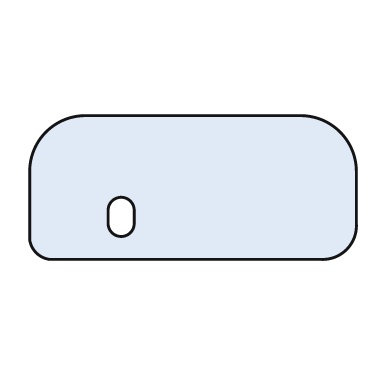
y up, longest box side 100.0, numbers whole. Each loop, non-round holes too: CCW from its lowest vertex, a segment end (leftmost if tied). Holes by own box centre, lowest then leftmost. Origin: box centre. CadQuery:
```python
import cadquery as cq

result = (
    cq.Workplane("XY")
    .moveTo(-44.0, -22.0)
    .lineTo(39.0, -22.0)
    .threePointArc((47.0, -19.0), (50.0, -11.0))
    .lineTo(50.0, 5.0)
    .threePointArc((45.0, 17.0), (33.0, 22.0))
    .lineTo(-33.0, 22.0)
    .threePointArc((-45.0, 17.0), (-50.0, 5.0))
    .lineTo(-50.0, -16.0)
    .threePointArc((-48.0, -20.0), (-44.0, -22.0))
    .close()
    .moveTo(-26.0, -11.0)
    .threePointArc((-22.0, -15.0), (-18.0, -11.0))
    .lineTo(-18.0, -7.0)
    .threePointArc((-22.0, -3.0), (-26.0, -7.0))
    .close()
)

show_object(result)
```